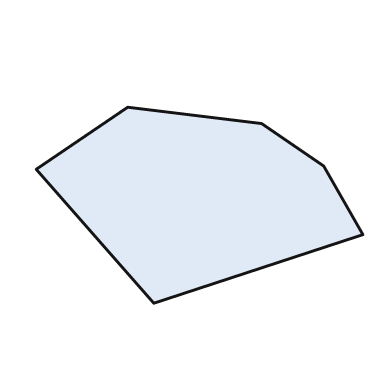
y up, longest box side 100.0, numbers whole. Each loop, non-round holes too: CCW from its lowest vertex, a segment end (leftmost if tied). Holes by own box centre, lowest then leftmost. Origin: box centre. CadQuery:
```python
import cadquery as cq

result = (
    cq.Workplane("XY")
    .moveTo(-14.0, -30.0)
    .lineTo(50.0, -9.0)
    .lineTo(38.0, 12.0)
    .lineTo(19.0, 25.0)
    .lineTo(-22.0, 30.0)
    .lineTo(-50.0, 11.0)
    .close()
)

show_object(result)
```